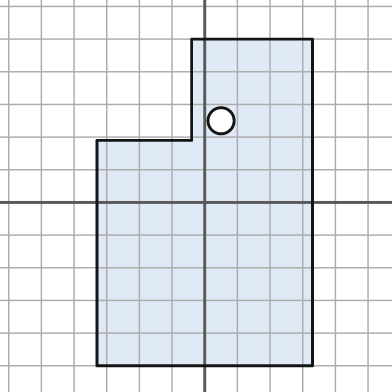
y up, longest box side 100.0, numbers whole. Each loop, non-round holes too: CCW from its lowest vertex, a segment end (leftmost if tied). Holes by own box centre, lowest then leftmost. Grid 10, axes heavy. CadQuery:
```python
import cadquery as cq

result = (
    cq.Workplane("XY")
    .moveTo(-33.0, -50.0)
    .lineTo(33.0, -50.0)
    .lineTo(33.0, 50.0)
    .lineTo(-4.0, 50.0)
    .lineTo(-4.0, 19.0)
    .lineTo(-33.0, 19.0)
    .close()
    .moveTo(5.0, 25.0)
    .circle(4.0)
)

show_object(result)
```